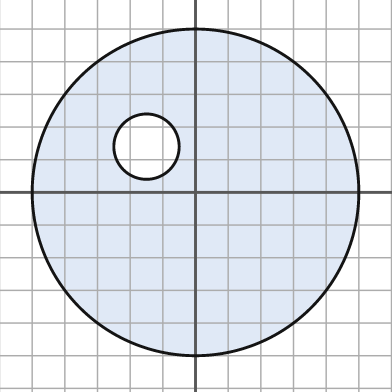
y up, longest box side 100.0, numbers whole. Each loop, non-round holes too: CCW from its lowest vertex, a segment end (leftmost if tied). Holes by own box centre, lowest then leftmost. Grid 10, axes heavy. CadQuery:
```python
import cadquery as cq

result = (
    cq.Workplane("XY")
    .moveTo(0.0, 0.0)
    .circle(50.0)
    .moveTo(-15.0, 14.0)
    .circle(10.0)
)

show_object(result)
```